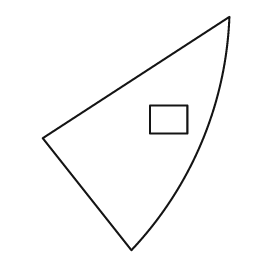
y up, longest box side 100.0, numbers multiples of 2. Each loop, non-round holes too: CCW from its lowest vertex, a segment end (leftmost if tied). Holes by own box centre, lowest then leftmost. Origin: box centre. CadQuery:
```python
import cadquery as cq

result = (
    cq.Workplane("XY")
    .moveTo(-2.0, -50.0)
    .threePointArc((28.0, -4.0), (40.0, 50.0))
    .lineTo(-40.0, -2.0)
    .close()
    .moveTo(6.0, 0.0)
    .lineTo(22.0, 0.0)
    .lineTo(22.0, 12.0)
    .lineTo(6.0, 12.0)
    .close()
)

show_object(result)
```